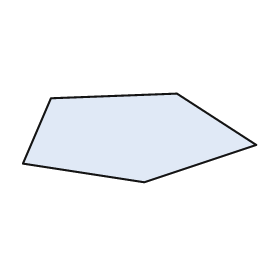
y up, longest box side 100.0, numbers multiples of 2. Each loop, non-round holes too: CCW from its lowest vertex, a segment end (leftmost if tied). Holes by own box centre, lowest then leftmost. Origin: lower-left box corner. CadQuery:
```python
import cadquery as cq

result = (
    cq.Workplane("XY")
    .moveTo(52.0, 0.0)
    .lineTo(100.0, 16.0)
    .lineTo(66.0, 38.0)
    .lineTo(12.0, 36.0)
    .lineTo(0.0, 8.0)
    .close()
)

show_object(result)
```